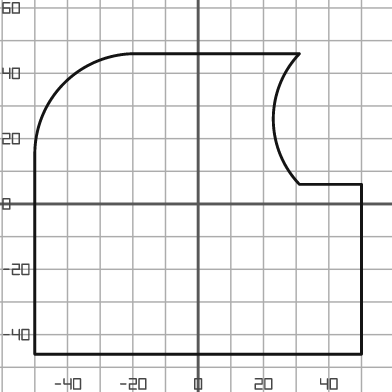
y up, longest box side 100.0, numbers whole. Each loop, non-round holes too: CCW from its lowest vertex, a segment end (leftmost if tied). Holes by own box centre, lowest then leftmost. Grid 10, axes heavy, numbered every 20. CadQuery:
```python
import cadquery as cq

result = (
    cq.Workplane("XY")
    .moveTo(-50.0, -46.0)
    .lineTo(50.0, -46.0)
    .lineTo(50.0, 6.0)
    .lineTo(31.0, 6.0)
    .threePointArc((23.0, 26.0), (31.0, 46.0))
    .lineTo(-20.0, 46.0)
    .threePointArc((-41.0, 37.0), (-50.0, 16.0))
    .close()
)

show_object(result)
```